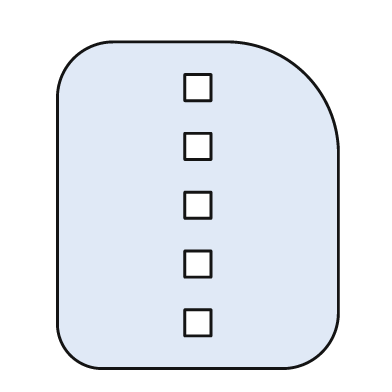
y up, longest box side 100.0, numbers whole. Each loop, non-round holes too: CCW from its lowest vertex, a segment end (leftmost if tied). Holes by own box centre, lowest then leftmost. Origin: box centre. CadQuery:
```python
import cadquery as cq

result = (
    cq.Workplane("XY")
    .moveTo(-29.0, -50.0)
    .lineTo(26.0, -50.0)
    .threePointArc((38.0, -45.0), (43.0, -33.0))
    .lineTo(43.0, 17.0)
    .threePointArc((33.0, 40.0), (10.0, 50.0))
    .lineTo(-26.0, 50.0)
    .threePointArc((-38.0, 45.0), (-43.0, 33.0))
    .lineTo(-43.0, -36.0)
    .threePointArc((-39.0, -46.0), (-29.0, -50.0))
    .close()
    .moveTo(-4.0, -40.0)
    .lineTo(4.0, -40.0)
    .lineTo(4.0, -32.0)
    .lineTo(-4.0, -32.0)
    .close()
    .moveTo(-4.0, -22.0)
    .lineTo(4.0, -22.0)
    .lineTo(4.0, -14.0)
    .lineTo(-4.0, -14.0)
    .close()
    .moveTo(-4.0, -4.0)
    .lineTo(4.0, -4.0)
    .lineTo(4.0, 4.0)
    .lineTo(-4.0, 4.0)
    .close()
    .moveTo(-4.0, 14.0)
    .lineTo(4.0, 14.0)
    .lineTo(4.0, 22.0)
    .lineTo(-4.0, 22.0)
    .close()
    .moveTo(-4.0, 32.0)
    .lineTo(4.0, 32.0)
    .lineTo(4.0, 40.0)
    .lineTo(-4.0, 40.0)
    .close()
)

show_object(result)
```